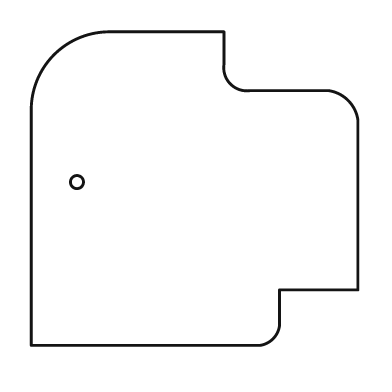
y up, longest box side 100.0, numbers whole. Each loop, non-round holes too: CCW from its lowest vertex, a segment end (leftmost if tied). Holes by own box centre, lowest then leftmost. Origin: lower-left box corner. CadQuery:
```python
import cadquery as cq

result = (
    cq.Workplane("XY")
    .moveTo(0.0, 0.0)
    .lineTo(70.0, 0.0)
    .threePointArc((74.0, 2.0), (76.0, 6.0))
    .lineTo(76.0, 17.0)
    .lineTo(100.0, 17.0)
    .lineTo(100.0, 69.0)
    .threePointArc((97.0, 75.0), (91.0, 78.0))
    .lineTo(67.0, 78.0)
    .threePointArc((61.0, 80.0), (59.0, 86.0))
    .lineTo(59.0, 96.0)
    .lineTo(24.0, 96.0)
    .threePointArc((7.0, 89.0), (0.0, 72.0))
    .close()
    .moveTo(14.0, 50.0)
    .circle(2.0)
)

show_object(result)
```